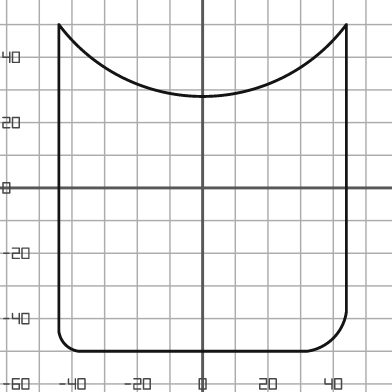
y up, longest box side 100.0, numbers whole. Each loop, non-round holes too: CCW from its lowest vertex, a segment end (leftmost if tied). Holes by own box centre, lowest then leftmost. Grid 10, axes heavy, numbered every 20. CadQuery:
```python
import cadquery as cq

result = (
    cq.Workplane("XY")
    .moveTo(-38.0, -50.0)
    .lineTo(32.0, -50.0)
    .threePointArc((40.0, -46.0), (44.0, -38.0))
    .lineTo(44.0, 50.0)
    .threePointArc((0.0, 28.0), (-44.0, 50.0))
    .lineTo(-44.0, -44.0)
    .threePointArc((-42.0, -48.0), (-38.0, -50.0))
    .close()
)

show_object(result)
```